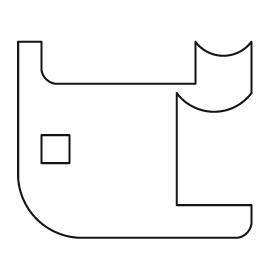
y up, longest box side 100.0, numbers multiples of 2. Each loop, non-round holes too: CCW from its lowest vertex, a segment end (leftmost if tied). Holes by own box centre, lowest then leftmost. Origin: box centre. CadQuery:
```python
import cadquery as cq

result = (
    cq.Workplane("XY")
    .moveTo(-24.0, -42.0)
    .lineTo(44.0, -42.0)
    .threePointArc((48.0, -40.0), (50.0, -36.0))
    .lineTo(50.0, -28.0)
    .lineTo(18.0, -28.0)
    .lineTo(18.0, 20.0)
    .threePointArc((34.0, 12.0), (50.0, 20.0))
    .lineTo(50.0, 42.0)
    .threePointArc((38.0, 36.0), (26.0, 42.0))
    .lineTo(26.0, 24.0)
    .lineTo(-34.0, 24.0)
    .threePointArc((-38.0, 26.0), (-40.0, 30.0))
    .lineTo(-40.0, 42.0)
    .lineTo(-50.0, 42.0)
    .lineTo(-50.0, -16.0)
    .threePointArc((-42.0, -34.0), (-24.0, -42.0))
    .close()
    .moveTo(-40.0, -10.0)
    .lineTo(-28.0, -10.0)
    .lineTo(-28.0, 2.0)
    .lineTo(-40.0, 2.0)
    .close()
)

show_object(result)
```